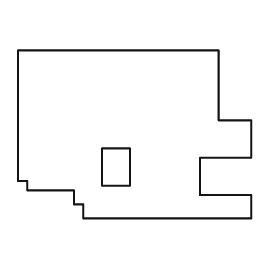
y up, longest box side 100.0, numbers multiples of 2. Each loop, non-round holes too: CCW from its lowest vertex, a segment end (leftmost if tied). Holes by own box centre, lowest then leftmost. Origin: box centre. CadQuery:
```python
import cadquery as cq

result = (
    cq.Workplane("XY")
    .moveTo(-22.0, -36.0)
    .lineTo(50.0, -36.0)
    .lineTo(50.0, -26.0)
    .lineTo(28.0, -26.0)
    .lineTo(28.0, -10.0)
    .lineTo(50.0, -10.0)
    .lineTo(50.0, 6.0)
    .lineTo(36.0, 6.0)
    .lineTo(36.0, 36.0)
    .lineTo(-50.0, 36.0)
    .lineTo(-50.0, -20.0)
    .lineTo(-46.0, -20.0)
    .lineTo(-46.0, -24.0)
    .lineTo(-26.0, -24.0)
    .lineTo(-26.0, -30.0)
    .lineTo(-22.0, -30.0)
    .close()
    .moveTo(-14.0, -22.0)
    .lineTo(-2.0, -22.0)
    .lineTo(-2.0, -6.0)
    .lineTo(-14.0, -6.0)
    .close()
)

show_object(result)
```